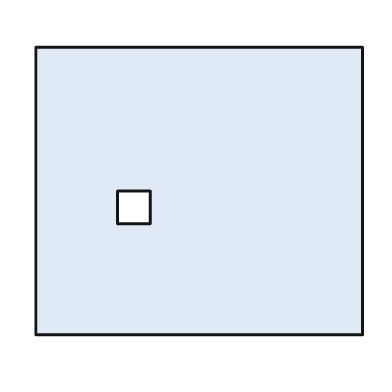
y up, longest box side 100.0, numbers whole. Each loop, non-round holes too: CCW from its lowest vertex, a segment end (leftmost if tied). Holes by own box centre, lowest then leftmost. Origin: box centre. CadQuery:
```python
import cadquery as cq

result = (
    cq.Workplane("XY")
    .moveTo(-50.0, -44.0)
    .lineTo(50.0, -44.0)
    .lineTo(50.0, 44.0)
    .lineTo(-50.0, 44.0)
    .close()
    .moveTo(-25.0, -10.0)
    .lineTo(-15.0, -10.0)
    .lineTo(-15.0, 0.0)
    .lineTo(-25.0, 0.0)
    .close()
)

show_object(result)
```